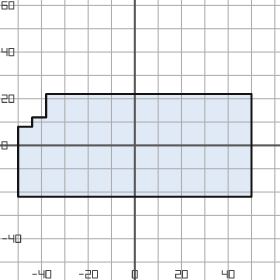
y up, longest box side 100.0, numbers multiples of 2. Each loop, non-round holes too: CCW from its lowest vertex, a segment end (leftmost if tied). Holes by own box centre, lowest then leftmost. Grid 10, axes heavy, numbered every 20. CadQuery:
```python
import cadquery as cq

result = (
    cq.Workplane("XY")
    .moveTo(-50.0, -22.0)
    .lineTo(50.0, -22.0)
    .lineTo(50.0, 22.0)
    .lineTo(-38.0, 22.0)
    .lineTo(-38.0, 12.0)
    .lineTo(-44.0, 12.0)
    .lineTo(-44.0, 8.0)
    .lineTo(-50.0, 8.0)
    .close()
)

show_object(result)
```